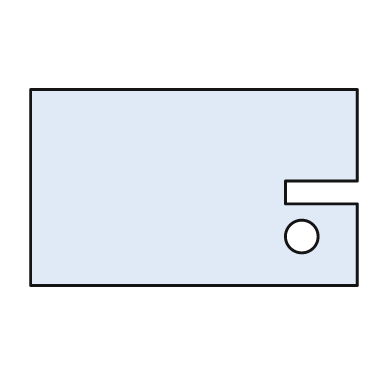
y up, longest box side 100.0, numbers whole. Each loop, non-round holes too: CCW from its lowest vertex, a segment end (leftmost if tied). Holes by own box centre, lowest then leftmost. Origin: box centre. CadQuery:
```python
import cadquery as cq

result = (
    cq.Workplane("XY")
    .moveTo(-50.0, -30.0)
    .lineTo(50.0, -30.0)
    .lineTo(50.0, -5.0)
    .lineTo(28.0, -5.0)
    .lineTo(28.0, 2.0)
    .lineTo(50.0, 2.0)
    .lineTo(50.0, 30.0)
    .lineTo(-50.0, 30.0)
    .close()
    .moveTo(33.0, -15.0)
    .circle(5.0)
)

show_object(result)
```